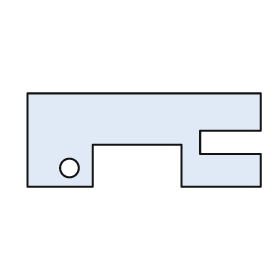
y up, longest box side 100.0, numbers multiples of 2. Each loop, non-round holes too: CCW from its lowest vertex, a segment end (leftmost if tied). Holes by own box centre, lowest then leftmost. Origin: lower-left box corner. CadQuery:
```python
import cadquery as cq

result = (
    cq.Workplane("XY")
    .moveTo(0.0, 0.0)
    .lineTo(28.0, 0.0)
    .lineTo(28.0, 18.0)
    .lineTo(66.0, 18.0)
    .lineTo(66.0, 0.0)
    .lineTo(100.0, 0.0)
    .lineTo(100.0, 14.0)
    .lineTo(74.0, 14.0)
    .lineTo(74.0, 24.0)
    .lineTo(100.0, 24.0)
    .lineTo(100.0, 40.0)
    .lineTo(0.0, 40.0)
    .close()
    .moveTo(18.0, 8.0)
    .circle(4.0)
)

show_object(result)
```